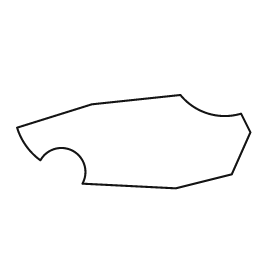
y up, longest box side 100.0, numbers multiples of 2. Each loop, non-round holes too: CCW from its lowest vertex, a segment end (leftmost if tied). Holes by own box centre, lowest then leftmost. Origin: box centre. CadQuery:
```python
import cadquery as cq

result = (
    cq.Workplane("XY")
    .moveTo(18.0, -20.0)
    .lineTo(42.0, -14.0)
    .lineTo(50.0, 4.0)
    .lineTo(46.0, 12.0)
    .threePointArc((32.0, 12.0), (20.0, 20.0))
    .lineTo(-18.0, 16.0)
    .lineTo(-50.0, 6.0)
    .threePointArc((-46.0, -2.0), (-40.0, -8.0))
    .threePointArc((-26.0, -4.0), (-22.0, -18.0))
    .close()
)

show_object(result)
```